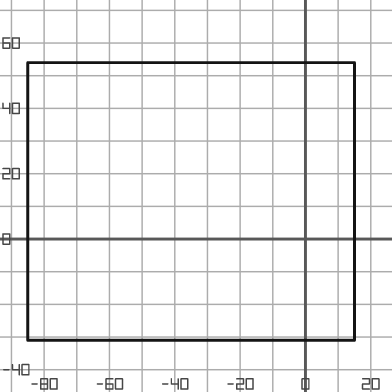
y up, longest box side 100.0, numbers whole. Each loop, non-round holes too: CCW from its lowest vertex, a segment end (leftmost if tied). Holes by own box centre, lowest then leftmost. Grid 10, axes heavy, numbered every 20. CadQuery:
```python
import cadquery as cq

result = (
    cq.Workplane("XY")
    .moveTo(-85.0, -31.0)
    .lineTo(15.0, -31.0)
    .lineTo(15.0, 54.0)
    .lineTo(-85.0, 54.0)
    .close()
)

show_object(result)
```